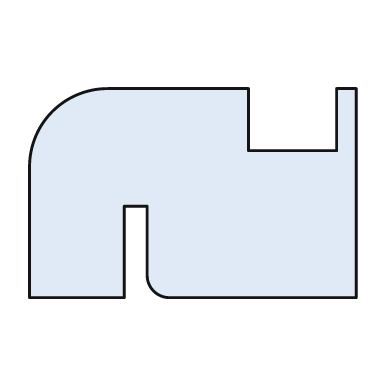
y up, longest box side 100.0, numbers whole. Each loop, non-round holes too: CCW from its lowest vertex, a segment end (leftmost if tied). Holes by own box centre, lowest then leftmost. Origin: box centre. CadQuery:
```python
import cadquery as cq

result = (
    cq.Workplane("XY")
    .moveTo(-50.0, -32.0)
    .lineTo(-21.0, -32.0)
    .lineTo(-21.0, -4.0)
    .lineTo(-14.0, -4.0)
    .lineTo(-14.0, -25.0)
    .threePointArc((-12.0, -30.0), (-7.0, -32.0))
    .lineTo(50.0, -32.0)
    .lineTo(50.0, 32.0)
    .lineTo(44.0, 32.0)
    .lineTo(44.0, 13.0)
    .lineTo(17.0, 13.0)
    .lineTo(17.0, 32.0)
    .lineTo(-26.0, 32.0)
    .threePointArc((-43.0, 25.0), (-50.0, 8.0))
    .close()
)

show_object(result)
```